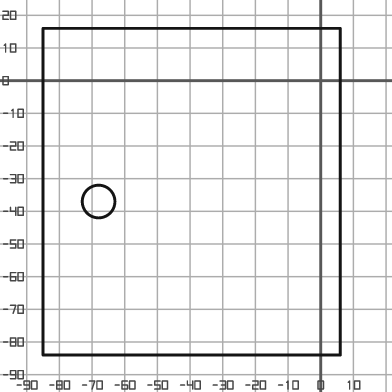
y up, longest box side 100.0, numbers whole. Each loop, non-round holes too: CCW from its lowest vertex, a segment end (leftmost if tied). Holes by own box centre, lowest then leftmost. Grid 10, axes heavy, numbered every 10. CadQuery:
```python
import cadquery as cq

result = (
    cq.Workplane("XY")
    .moveTo(-85.0, -84.0)
    .lineTo(6.0, -84.0)
    .lineTo(6.0, 16.0)
    .lineTo(-85.0, 16.0)
    .close()
    .moveTo(-68.0, -37.0)
    .circle(5.0)
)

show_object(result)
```